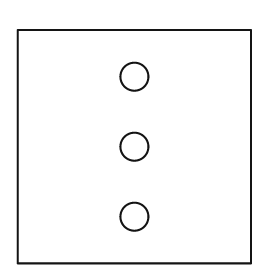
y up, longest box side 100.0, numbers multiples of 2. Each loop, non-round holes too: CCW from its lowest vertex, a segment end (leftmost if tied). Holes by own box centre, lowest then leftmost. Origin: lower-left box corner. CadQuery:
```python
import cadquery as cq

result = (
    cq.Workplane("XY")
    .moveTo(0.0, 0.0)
    .lineTo(100.0, 0.0)
    .lineTo(100.0, 100.0)
    .lineTo(0.0, 100.0)
    .close()
    .moveTo(50.0, 20.0)
    .circle(6.0)
    .moveTo(50.0, 50.0)
    .circle(6.0)
    .moveTo(50.0, 80.0)
    .circle(6.0)
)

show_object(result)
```